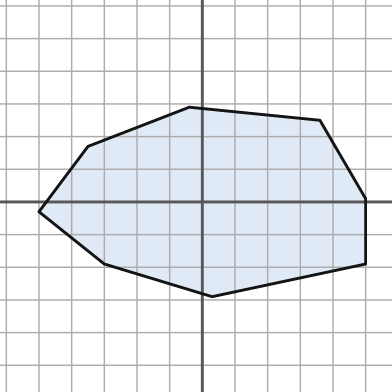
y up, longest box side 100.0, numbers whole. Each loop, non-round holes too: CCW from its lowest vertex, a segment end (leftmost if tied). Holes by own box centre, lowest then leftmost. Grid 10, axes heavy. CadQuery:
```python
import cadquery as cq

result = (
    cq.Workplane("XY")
    .moveTo(3.0, -29.0)
    .lineTo(50.0, -19.0)
    .lineTo(50.0, 1.0)
    .lineTo(36.0, 25.0)
    .lineTo(-4.0, 29.0)
    .lineTo(-35.0, 17.0)
    .lineTo(-50.0, -3.0)
    .lineTo(-30.0, -19.0)
    .close()
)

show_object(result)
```